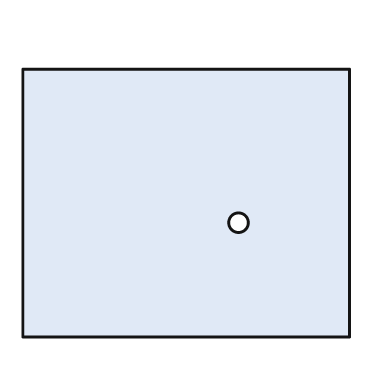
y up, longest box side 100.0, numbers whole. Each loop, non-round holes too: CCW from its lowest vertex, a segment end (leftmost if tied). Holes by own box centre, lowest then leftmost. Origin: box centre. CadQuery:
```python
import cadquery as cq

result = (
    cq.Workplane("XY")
    .moveTo(-50.0, -41.0)
    .lineTo(50.0, -41.0)
    .lineTo(50.0, 41.0)
    .lineTo(-50.0, 41.0)
    .close()
    .moveTo(16.0, -6.0)
    .circle(3.0)
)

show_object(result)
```